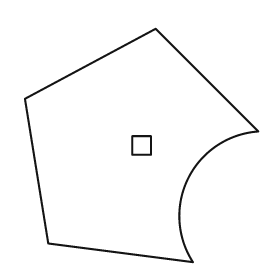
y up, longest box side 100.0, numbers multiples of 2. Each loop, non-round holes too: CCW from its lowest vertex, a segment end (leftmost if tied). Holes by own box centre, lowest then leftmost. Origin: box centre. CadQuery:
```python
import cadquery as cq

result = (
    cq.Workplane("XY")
    .moveTo(22.0, -50.0)
    .threePointArc((20.0, -14.0), (50.0, 6.0))
    .lineTo(6.0, 50.0)
    .lineTo(-50.0, 20.0)
    .lineTo(-40.0, -42.0)
    .close()
    .moveTo(-4.0, -4.0)
    .lineTo(4.0, -4.0)
    .lineTo(4.0, 4.0)
    .lineTo(-4.0, 4.0)
    .close()
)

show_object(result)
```